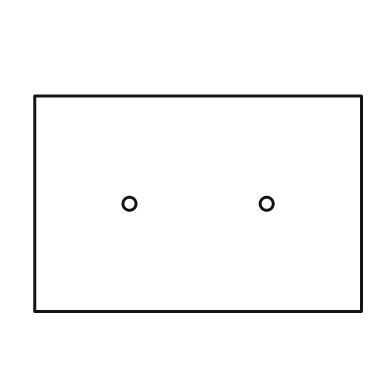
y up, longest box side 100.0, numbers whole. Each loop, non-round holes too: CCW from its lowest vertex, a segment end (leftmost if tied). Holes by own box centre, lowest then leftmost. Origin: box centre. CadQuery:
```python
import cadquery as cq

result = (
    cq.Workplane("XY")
    .moveTo(-50.0, -33.0)
    .lineTo(50.0, -33.0)
    .lineTo(50.0, 33.0)
    .lineTo(-50.0, 33.0)
    .close()
    .moveTo(-21.0, 0.0)
    .circle(2.0)
    .moveTo(21.0, 0.0)
    .circle(2.0)
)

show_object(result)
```